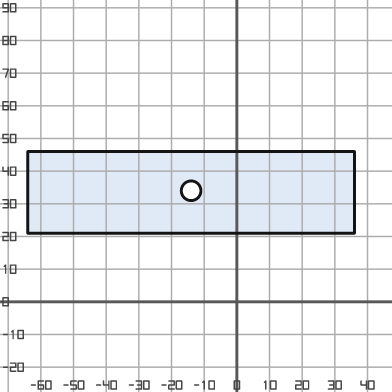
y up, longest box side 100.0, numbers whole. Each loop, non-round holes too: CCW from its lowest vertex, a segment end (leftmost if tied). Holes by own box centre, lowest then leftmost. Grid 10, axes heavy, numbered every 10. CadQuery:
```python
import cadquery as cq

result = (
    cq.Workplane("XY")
    .moveTo(-64.0, 21.0)
    .lineTo(36.0, 21.0)
    .lineTo(36.0, 46.0)
    .lineTo(-64.0, 46.0)
    .close()
    .moveTo(-14.0, 34.0)
    .circle(3.0)
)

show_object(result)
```